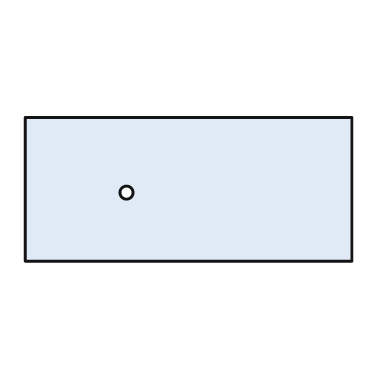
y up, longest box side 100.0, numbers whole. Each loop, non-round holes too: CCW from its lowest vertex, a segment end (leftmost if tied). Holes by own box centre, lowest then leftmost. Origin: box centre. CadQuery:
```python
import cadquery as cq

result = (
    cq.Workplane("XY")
    .moveTo(-50.0, -22.0)
    .lineTo(50.0, -22.0)
    .lineTo(50.0, 22.0)
    .lineTo(-50.0, 22.0)
    .close()
    .moveTo(-19.0, -1.0)
    .circle(2.0)
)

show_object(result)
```